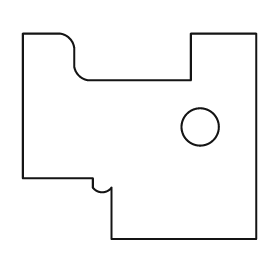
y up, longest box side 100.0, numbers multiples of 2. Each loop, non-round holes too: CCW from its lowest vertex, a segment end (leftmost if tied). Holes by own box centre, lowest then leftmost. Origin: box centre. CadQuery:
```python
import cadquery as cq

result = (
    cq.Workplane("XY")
    .moveTo(-12.0, -44.0)
    .lineTo(50.0, -44.0)
    .lineTo(50.0, 44.0)
    .lineTo(22.0, 44.0)
    .lineTo(22.0, 24.0)
    .lineTo(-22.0, 24.0)
    .threePointArc((-26.0, 26.0), (-28.0, 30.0))
    .lineTo(-28.0, 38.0)
    .threePointArc((-30.0, 42.0), (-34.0, 44.0))
    .lineTo(-50.0, 44.0)
    .lineTo(-50.0, -18.0)
    .lineTo(-20.0, -18.0)
    .lineTo(-20.0, -22.0)
    .threePointArc((-16.0, -24.0), (-12.0, -22.0))
    .close()
    .moveTo(26.0, 4.0)
    .circle(8.0)
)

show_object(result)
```